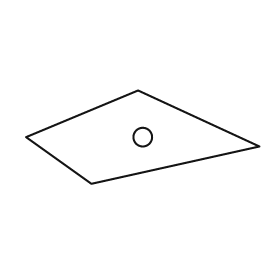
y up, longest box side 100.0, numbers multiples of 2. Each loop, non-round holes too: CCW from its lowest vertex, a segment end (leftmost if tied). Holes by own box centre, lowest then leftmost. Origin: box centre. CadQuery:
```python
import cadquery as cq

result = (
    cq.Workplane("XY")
    .moveTo(-22.0, -20.0)
    .lineTo(50.0, -4.0)
    .lineTo(-2.0, 20.0)
    .lineTo(-50.0, 0.0)
    .close()
    .moveTo(0.0, 0.0)
    .circle(4.0)
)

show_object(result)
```